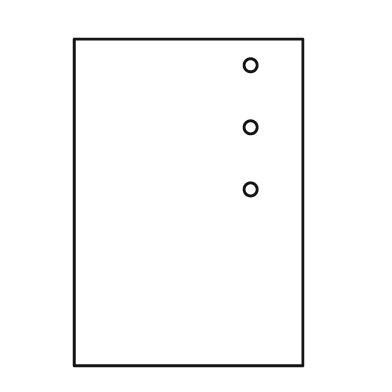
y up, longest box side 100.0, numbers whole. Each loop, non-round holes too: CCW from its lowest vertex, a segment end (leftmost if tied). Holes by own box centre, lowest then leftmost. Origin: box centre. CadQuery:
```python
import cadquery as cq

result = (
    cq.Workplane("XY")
    .moveTo(-35.0, -50.0)
    .lineTo(35.0, -50.0)
    .lineTo(35.0, 50.0)
    .lineTo(-35.0, 50.0)
    .close()
    .moveTo(19.0, 4.0)
    .circle(2.0)
    .moveTo(19.0, 23.0)
    .circle(2.0)
    .moveTo(19.0, 42.0)
    .circle(2.0)
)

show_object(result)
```